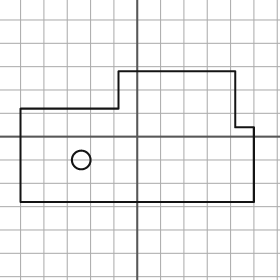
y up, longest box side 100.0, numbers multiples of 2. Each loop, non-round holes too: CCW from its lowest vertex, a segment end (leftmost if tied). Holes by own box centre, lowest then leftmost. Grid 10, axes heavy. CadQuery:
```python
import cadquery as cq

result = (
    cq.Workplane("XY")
    .moveTo(-50.0, -28.0)
    .lineTo(50.0, -28.0)
    .lineTo(50.0, 4.0)
    .lineTo(42.0, 4.0)
    .lineTo(42.0, 28.0)
    .lineTo(-8.0, 28.0)
    .lineTo(-8.0, 12.0)
    .lineTo(-50.0, 12.0)
    .close()
    .moveTo(-24.0, -10.0)
    .circle(4.0)
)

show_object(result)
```